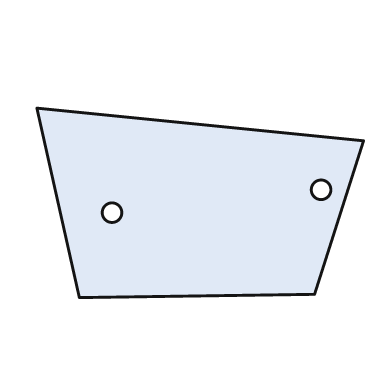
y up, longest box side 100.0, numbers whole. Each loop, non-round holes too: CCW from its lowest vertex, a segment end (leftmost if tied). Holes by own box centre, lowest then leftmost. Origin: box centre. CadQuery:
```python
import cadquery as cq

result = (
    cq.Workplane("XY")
    .moveTo(-37.0, -29.0)
    .lineTo(35.0, -28.0)
    .lineTo(50.0, 19.0)
    .lineTo(-50.0, 29.0)
    .close()
    .moveTo(-27.0, -3.0)
    .circle(3.0)
    .moveTo(37.0, 4.0)
    .circle(3.0)
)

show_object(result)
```